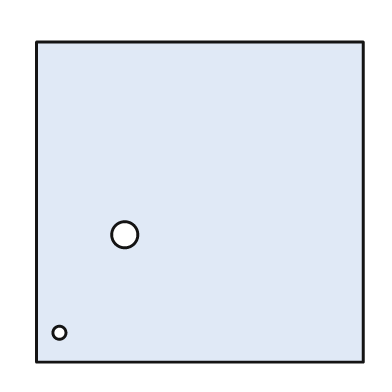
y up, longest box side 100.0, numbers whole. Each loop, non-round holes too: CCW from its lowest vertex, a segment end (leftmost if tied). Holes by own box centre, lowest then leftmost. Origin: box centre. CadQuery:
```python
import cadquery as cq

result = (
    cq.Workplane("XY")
    .moveTo(-50.0, -49.0)
    .lineTo(50.0, -49.0)
    .lineTo(50.0, 49.0)
    .lineTo(-50.0, 49.0)
    .close()
    .moveTo(-43.0, -40.0)
    .circle(2.0)
    .moveTo(-23.0, -10.0)
    .circle(4.0)
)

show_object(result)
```